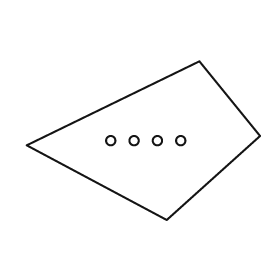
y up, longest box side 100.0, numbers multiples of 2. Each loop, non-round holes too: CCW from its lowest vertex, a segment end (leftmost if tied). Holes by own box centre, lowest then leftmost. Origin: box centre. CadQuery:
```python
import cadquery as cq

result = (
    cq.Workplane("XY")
    .moveTo(10.0, -34.0)
    .lineTo(50.0, 2.0)
    .lineTo(24.0, 34.0)
    .lineTo(-50.0, -2.0)
    .close()
    .moveTo(-14.0, 0.0)
    .circle(2.0)
    .moveTo(-4.0, 0.0)
    .circle(2.0)
    .moveTo(6.0, 0.0)
    .circle(2.0)
    .moveTo(16.0, 0.0)
    .circle(2.0)
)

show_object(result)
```